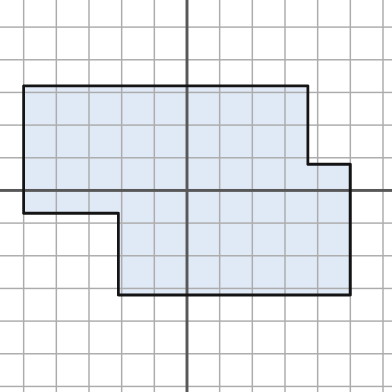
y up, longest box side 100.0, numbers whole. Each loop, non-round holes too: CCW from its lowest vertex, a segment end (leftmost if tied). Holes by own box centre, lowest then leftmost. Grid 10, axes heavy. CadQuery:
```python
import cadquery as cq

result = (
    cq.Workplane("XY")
    .moveTo(-21.0, -32.0)
    .lineTo(50.0, -32.0)
    .lineTo(50.0, 8.0)
    .lineTo(37.0, 8.0)
    .lineTo(37.0, 32.0)
    .lineTo(-50.0, 32.0)
    .lineTo(-50.0, -7.0)
    .lineTo(-21.0, -7.0)
    .close()
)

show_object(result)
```